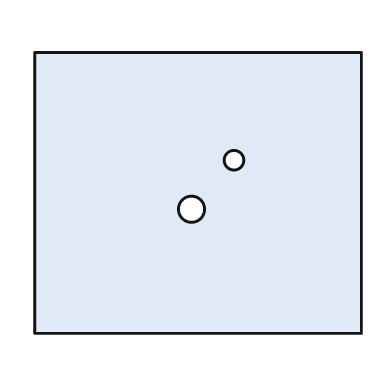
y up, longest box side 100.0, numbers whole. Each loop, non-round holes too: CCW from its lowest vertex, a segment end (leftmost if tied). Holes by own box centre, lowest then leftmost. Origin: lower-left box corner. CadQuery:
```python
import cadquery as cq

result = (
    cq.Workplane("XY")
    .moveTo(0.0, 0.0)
    .lineTo(100.0, 0.0)
    .lineTo(100.0, 86.0)
    .lineTo(0.0, 86.0)
    .close()
    .moveTo(48.0, 38.0)
    .circle(4.0)
    .moveTo(61.0, 53.0)
    .circle(3.0)
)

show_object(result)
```